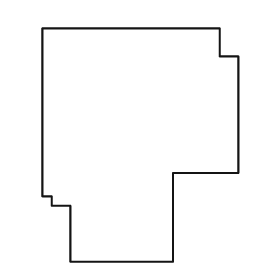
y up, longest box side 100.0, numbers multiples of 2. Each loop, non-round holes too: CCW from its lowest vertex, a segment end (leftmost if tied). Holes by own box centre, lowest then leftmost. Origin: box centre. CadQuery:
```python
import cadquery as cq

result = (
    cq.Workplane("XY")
    .moveTo(-30.0, -50.0)
    .lineTo(14.0, -50.0)
    .lineTo(14.0, -12.0)
    .lineTo(42.0, -12.0)
    .lineTo(42.0, 38.0)
    .lineTo(34.0, 38.0)
    .lineTo(34.0, 50.0)
    .lineTo(-42.0, 50.0)
    .lineTo(-42.0, -22.0)
    .lineTo(-38.0, -22.0)
    .lineTo(-38.0, -26.0)
    .lineTo(-30.0, -26.0)
    .close()
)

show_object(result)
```